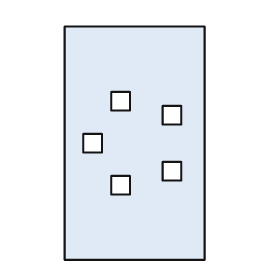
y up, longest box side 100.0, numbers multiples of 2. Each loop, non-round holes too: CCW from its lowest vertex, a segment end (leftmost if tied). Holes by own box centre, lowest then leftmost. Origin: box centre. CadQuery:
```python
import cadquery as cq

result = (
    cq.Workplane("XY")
    .moveTo(-30.0, -50.0)
    .lineTo(30.0, -50.0)
    .lineTo(30.0, 50.0)
    .lineTo(-30.0, 50.0)
    .close()
    .moveTo(-10.0, -22.0)
    .lineTo(-2.0, -22.0)
    .lineTo(-2.0, -14.0)
    .lineTo(-10.0, -14.0)
    .close()
    .moveTo(12.0, -16.0)
    .lineTo(20.0, -16.0)
    .lineTo(20.0, -8.0)
    .lineTo(12.0, -8.0)
    .close()
    .moveTo(-22.0, -4.0)
    .lineTo(-14.0, -4.0)
    .lineTo(-14.0, 4.0)
    .lineTo(-22.0, 4.0)
    .close()
    .moveTo(12.0, 8.0)
    .lineTo(20.0, 8.0)
    .lineTo(20.0, 16.0)
    .lineTo(12.0, 16.0)
    .close()
    .moveTo(-10.0, 14.0)
    .lineTo(-2.0, 14.0)
    .lineTo(-2.0, 22.0)
    .lineTo(-10.0, 22.0)
    .close()
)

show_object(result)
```